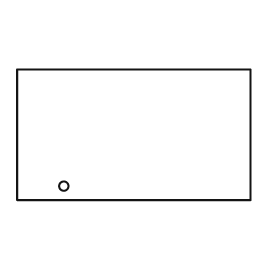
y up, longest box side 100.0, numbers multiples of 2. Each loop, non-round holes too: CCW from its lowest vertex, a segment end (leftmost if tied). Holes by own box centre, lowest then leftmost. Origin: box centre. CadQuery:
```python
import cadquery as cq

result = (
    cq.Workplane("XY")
    .moveTo(-50.0, -28.0)
    .lineTo(50.0, -28.0)
    .lineTo(50.0, 28.0)
    .lineTo(-50.0, 28.0)
    .close()
    .moveTo(-30.0, -22.0)
    .circle(2.0)
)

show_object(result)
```